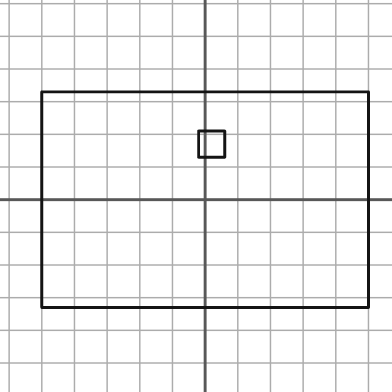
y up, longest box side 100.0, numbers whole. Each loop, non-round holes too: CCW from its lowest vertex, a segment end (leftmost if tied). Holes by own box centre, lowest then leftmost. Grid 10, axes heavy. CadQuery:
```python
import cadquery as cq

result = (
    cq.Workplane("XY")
    .moveTo(-50.0, -33.0)
    .lineTo(50.0, -33.0)
    .lineTo(50.0, 33.0)
    .lineTo(-50.0, 33.0)
    .close()
    .moveTo(-2.0, 13.0)
    .lineTo(6.0, 13.0)
    .lineTo(6.0, 21.0)
    .lineTo(-2.0, 21.0)
    .close()
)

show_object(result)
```